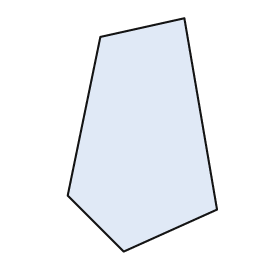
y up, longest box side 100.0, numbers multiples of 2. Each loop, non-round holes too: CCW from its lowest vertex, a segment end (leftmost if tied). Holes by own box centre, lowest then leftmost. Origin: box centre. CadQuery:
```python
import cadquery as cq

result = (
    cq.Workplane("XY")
    .moveTo(-8.0, -50.0)
    .lineTo(32.0, -32.0)
    .lineTo(18.0, 50.0)
    .lineTo(-18.0, 42.0)
    .lineTo(-32.0, -26.0)
    .close()
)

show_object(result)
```